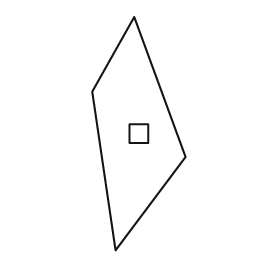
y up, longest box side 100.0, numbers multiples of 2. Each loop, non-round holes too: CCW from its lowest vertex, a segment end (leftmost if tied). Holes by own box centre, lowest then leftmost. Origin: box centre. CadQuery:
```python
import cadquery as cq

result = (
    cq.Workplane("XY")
    .moveTo(-10.0, -50.0)
    .lineTo(20.0, -10.0)
    .lineTo(-2.0, 50.0)
    .lineTo(-20.0, 18.0)
    .close()
    .moveTo(-4.0, -4.0)
    .lineTo(4.0, -4.0)
    .lineTo(4.0, 4.0)
    .lineTo(-4.0, 4.0)
    .close()
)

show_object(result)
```